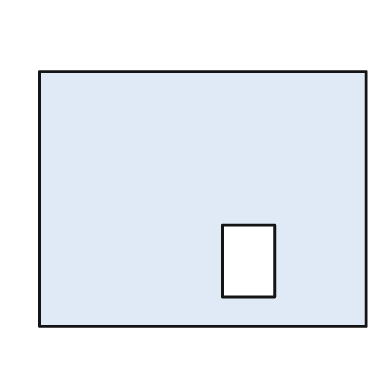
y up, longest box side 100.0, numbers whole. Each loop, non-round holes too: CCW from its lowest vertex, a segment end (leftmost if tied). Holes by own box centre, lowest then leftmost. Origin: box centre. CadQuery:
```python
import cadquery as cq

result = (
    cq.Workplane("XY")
    .moveTo(-50.0, -39.0)
    .lineTo(50.0, -39.0)
    .lineTo(50.0, 39.0)
    .lineTo(-50.0, 39.0)
    .close()
    .moveTo(6.0, -30.0)
    .lineTo(22.0, -30.0)
    .lineTo(22.0, -8.0)
    .lineTo(6.0, -8.0)
    .close()
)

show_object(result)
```